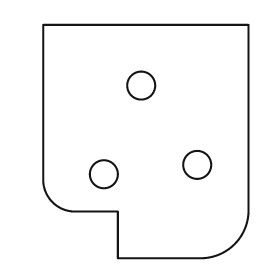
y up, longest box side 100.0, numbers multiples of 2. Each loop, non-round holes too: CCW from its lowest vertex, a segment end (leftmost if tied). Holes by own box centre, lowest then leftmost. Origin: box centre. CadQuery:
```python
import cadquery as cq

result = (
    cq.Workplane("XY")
    .moveTo(-12.0, -50.0)
    .lineTo(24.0, -50.0)
    .threePointArc((38.0, -44.0), (44.0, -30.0))
    .lineTo(44.0, 50.0)
    .lineTo(-44.0, 50.0)
    .lineTo(-44.0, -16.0)
    .threePointArc((-40.0, -26.0), (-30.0, -30.0))
    .lineTo(-12.0, -30.0)
    .close()
    .moveTo(-18.0, -14.0)
    .circle(6.0)
    .moveTo(22.0, -10.0)
    .circle(6.0)
    .moveTo(-2.0, 24.0)
    .circle(6.0)
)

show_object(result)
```